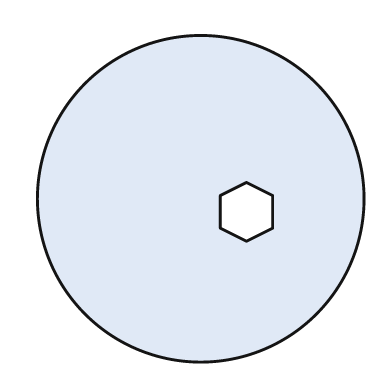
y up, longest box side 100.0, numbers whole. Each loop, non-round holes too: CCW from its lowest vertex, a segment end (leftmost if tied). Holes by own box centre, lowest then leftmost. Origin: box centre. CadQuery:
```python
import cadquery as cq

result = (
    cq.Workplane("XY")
    .moveTo(0.0, 0.0)
    .circle(50.0)
    .moveTo(14.0, -13.0)
    .lineTo(22.0, -9.0)
    .lineTo(22.0, 1.0)
    .lineTo(14.0, 5.0)
    .lineTo(6.0, 1.0)
    .lineTo(6.0, -9.0)
    .close()
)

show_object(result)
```